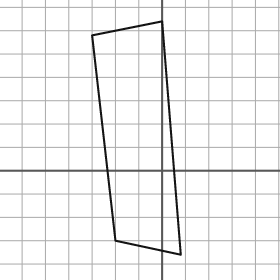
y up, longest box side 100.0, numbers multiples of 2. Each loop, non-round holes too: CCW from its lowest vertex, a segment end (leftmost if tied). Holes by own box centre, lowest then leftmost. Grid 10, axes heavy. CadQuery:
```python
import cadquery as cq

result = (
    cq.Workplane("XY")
    .moveTo(8.0, -36.0)
    .lineTo(0.0, 64.0)
    .lineTo(-30.0, 58.0)
    .lineTo(-20.0, -30.0)
    .close()
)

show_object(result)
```